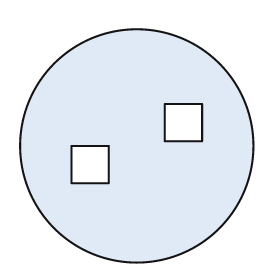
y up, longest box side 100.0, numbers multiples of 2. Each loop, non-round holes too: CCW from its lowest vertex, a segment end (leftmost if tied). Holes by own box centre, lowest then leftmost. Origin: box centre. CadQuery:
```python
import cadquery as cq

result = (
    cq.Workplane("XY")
    .moveTo(0.0, 0.0)
    .circle(50.0)
    .moveTo(-28.0, -16.0)
    .lineTo(-12.0, -16.0)
    .lineTo(-12.0, 0.0)
    .lineTo(-28.0, 0.0)
    .close()
    .moveTo(12.0, 2.0)
    .lineTo(28.0, 2.0)
    .lineTo(28.0, 18.0)
    .lineTo(12.0, 18.0)
    .close()
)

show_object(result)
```